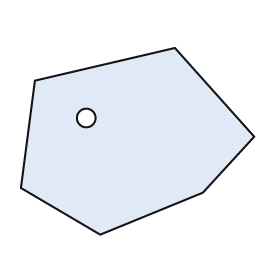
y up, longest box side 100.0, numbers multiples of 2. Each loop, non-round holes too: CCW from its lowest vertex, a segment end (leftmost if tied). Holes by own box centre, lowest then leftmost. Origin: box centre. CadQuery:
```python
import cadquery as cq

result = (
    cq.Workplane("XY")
    .moveTo(-16.0, -40.0)
    .lineTo(28.0, -22.0)
    .lineTo(50.0, 2.0)
    .lineTo(16.0, 40.0)
    .lineTo(-44.0, 26.0)
    .lineTo(-50.0, -20.0)
    .close()
    .moveTo(-22.0, 10.0)
    .circle(4.0)
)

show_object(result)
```